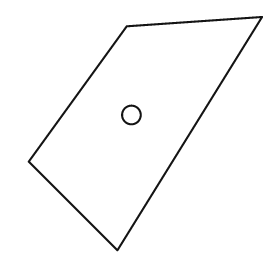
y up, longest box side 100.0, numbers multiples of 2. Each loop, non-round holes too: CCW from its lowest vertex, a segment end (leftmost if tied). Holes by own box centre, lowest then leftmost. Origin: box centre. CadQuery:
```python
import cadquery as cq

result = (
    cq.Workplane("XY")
    .moveTo(-12.0, -50.0)
    .lineTo(50.0, 50.0)
    .lineTo(-8.0, 46.0)
    .lineTo(-50.0, -12.0)
    .close()
    .moveTo(-6.0, 8.0)
    .circle(4.0)
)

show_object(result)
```